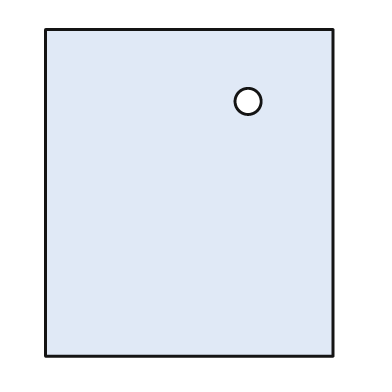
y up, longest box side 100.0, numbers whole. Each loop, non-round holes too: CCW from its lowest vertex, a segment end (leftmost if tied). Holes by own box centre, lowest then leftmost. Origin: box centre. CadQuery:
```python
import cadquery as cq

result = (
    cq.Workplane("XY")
    .moveTo(-44.0, -50.0)
    .lineTo(44.0, -50.0)
    .lineTo(44.0, 50.0)
    .lineTo(-44.0, 50.0)
    .close()
    .moveTo(18.0, 28.0)
    .circle(4.0)
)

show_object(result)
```